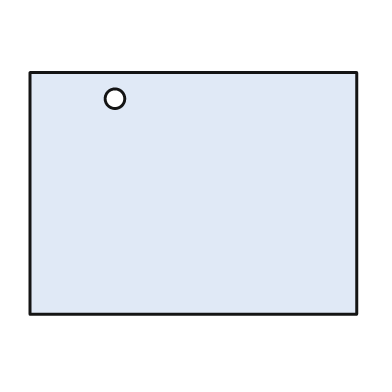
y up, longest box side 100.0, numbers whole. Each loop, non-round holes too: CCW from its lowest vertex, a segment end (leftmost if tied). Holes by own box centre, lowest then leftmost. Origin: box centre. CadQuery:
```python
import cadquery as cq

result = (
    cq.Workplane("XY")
    .moveTo(-50.0, -37.0)
    .lineTo(50.0, -37.0)
    .lineTo(50.0, 37.0)
    .lineTo(-50.0, 37.0)
    .close()
    .moveTo(-24.0, 29.0)
    .circle(3.0)
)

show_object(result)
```